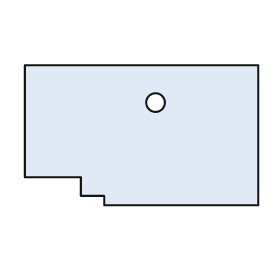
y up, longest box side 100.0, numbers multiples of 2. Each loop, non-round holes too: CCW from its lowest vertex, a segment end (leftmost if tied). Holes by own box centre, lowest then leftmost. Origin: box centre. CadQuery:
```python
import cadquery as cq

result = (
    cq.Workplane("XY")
    .moveTo(-16.0, -30.0)
    .lineTo(50.0, -30.0)
    .lineTo(50.0, 30.0)
    .lineTo(-50.0, 30.0)
    .lineTo(-50.0, -18.0)
    .lineTo(-26.0, -18.0)
    .lineTo(-26.0, -26.0)
    .lineTo(-16.0, -26.0)
    .close()
    .moveTo(6.0, 14.0)
    .circle(4.0)
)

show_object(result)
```